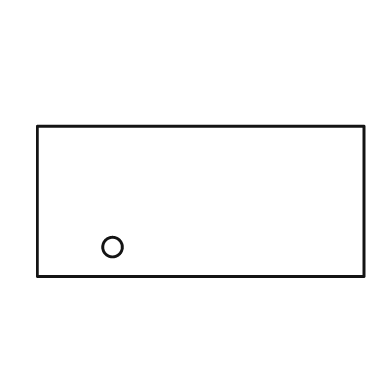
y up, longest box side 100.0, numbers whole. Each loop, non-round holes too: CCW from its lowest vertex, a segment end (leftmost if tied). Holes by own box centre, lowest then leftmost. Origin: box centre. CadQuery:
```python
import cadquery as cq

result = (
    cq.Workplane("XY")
    .moveTo(-50.0, -23.0)
    .lineTo(50.0, -23.0)
    .lineTo(50.0, 23.0)
    .lineTo(-50.0, 23.0)
    .close()
    .moveTo(-27.0, -14.0)
    .circle(3.0)
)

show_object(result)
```